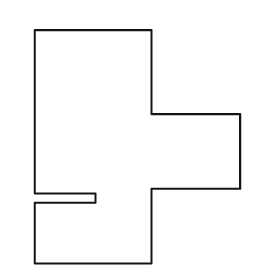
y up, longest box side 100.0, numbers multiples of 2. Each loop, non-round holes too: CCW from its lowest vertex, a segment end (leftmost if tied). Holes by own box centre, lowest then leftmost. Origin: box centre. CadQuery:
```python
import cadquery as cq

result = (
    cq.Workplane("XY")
    .moveTo(-44.0, -50.0)
    .lineTo(6.0, -50.0)
    .lineTo(6.0, -18.0)
    .lineTo(44.0, -18.0)
    .lineTo(44.0, 14.0)
    .lineTo(6.0, 14.0)
    .lineTo(6.0, 50.0)
    .lineTo(-44.0, 50.0)
    .lineTo(-44.0, -20.0)
    .lineTo(-18.0, -20.0)
    .lineTo(-18.0, -24.0)
    .lineTo(-44.0, -24.0)
    .close()
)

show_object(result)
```